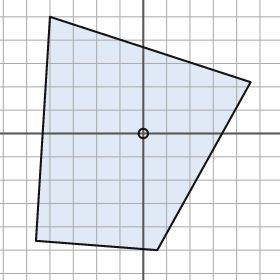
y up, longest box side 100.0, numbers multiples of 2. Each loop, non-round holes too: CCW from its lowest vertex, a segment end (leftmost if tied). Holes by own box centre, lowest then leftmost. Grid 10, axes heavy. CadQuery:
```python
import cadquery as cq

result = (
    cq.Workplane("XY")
    .moveTo(6.0, -50.0)
    .lineTo(46.0, 22.0)
    .lineTo(-40.0, 50.0)
    .lineTo(-46.0, -46.0)
    .close()
    .moveTo(0.0, 0.0)
    .circle(2.0)
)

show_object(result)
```